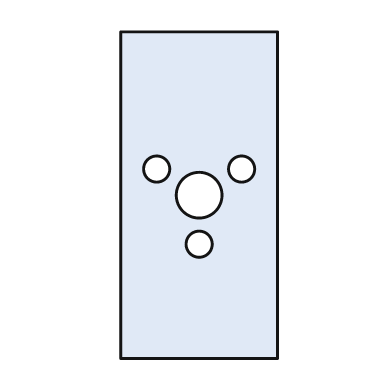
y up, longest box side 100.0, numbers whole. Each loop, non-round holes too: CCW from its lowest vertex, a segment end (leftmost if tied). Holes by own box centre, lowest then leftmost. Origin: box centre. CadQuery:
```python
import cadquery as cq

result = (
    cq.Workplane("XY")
    .moveTo(-24.0, -50.0)
    .lineTo(24.0, -50.0)
    .lineTo(24.0, 50.0)
    .lineTo(-24.0, 50.0)
    .close()
    .moveTo(0.0, -15.0)
    .circle(4.0)
    .moveTo(0.0, 0.0)
    .circle(7.0)
    .moveTo(-13.0, 8.0)
    .circle(4.0)
    .moveTo(13.0, 8.0)
    .circle(4.0)
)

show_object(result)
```